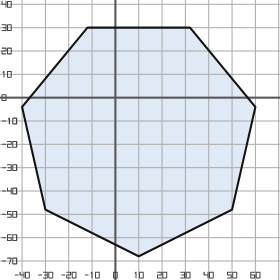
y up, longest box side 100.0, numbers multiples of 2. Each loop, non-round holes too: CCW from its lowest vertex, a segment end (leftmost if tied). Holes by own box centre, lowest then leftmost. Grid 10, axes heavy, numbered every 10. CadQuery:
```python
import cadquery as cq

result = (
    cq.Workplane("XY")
    .moveTo(10.0, -68.0)
    .lineTo(50.0, -48.0)
    .lineTo(60.0, -4.0)
    .lineTo(32.0, 30.0)
    .lineTo(-12.0, 30.0)
    .lineTo(-40.0, -4.0)
    .lineTo(-30.0, -48.0)
    .close()
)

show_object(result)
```